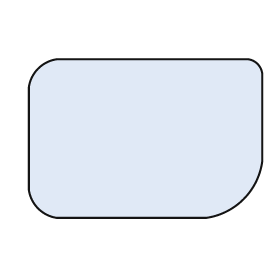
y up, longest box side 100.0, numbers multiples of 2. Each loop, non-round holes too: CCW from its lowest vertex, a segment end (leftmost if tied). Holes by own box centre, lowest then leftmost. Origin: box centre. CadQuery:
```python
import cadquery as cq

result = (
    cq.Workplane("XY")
    .moveTo(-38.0, -34.0)
    .lineTo(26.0, -34.0)
    .threePointArc((42.0, -26.0), (50.0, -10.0))
    .lineTo(50.0, 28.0)
    .threePointArc((48.0, 32.0), (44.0, 34.0))
    .lineTo(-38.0, 34.0)
    .threePointArc((-46.0, 30.0), (-50.0, 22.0))
    .lineTo(-50.0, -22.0)
    .threePointArc((-46.0, -30.0), (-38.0, -34.0))
    .close()
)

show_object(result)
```